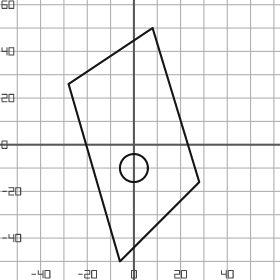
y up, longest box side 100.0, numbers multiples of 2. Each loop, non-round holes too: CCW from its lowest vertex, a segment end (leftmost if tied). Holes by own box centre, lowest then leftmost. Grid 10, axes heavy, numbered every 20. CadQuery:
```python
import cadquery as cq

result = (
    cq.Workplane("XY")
    .moveTo(-6.0, -50.0)
    .lineTo(28.0, -16.0)
    .lineTo(8.0, 50.0)
    .lineTo(-28.0, 26.0)
    .close()
    .moveTo(0.0, -10.0)
    .circle(6.0)
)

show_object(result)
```